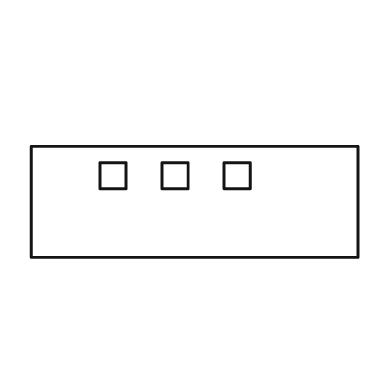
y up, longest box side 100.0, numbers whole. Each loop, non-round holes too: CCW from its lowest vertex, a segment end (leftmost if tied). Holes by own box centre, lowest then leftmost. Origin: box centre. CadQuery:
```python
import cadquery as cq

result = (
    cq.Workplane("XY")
    .moveTo(-50.0, -17.0)
    .lineTo(50.0, -17.0)
    .lineTo(50.0, 17.0)
    .lineTo(-50.0, 17.0)
    .close()
    .moveTo(-29.0, 4.0)
    .lineTo(-21.0, 4.0)
    .lineTo(-21.0, 12.0)
    .lineTo(-29.0, 12.0)
    .close()
    .moveTo(-10.0, 4.0)
    .lineTo(-2.0, 4.0)
    .lineTo(-2.0, 12.0)
    .lineTo(-10.0, 12.0)
    .close()
    .moveTo(9.0, 4.0)
    .lineTo(17.0, 4.0)
    .lineTo(17.0, 12.0)
    .lineTo(9.0, 12.0)
    .close()
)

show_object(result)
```